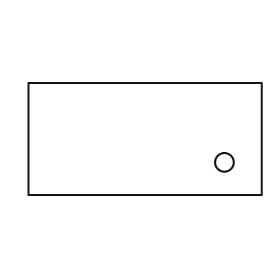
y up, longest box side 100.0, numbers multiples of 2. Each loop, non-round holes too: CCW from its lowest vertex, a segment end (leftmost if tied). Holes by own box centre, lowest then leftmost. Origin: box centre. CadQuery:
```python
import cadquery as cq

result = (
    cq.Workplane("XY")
    .moveTo(-50.0, -24.0)
    .lineTo(50.0, -24.0)
    .lineTo(50.0, 24.0)
    .lineTo(-50.0, 24.0)
    .close()
    .moveTo(34.0, -10.0)
    .circle(4.0)
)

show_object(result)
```